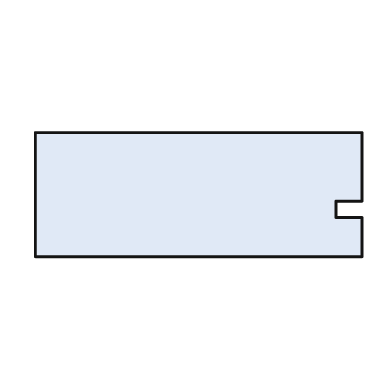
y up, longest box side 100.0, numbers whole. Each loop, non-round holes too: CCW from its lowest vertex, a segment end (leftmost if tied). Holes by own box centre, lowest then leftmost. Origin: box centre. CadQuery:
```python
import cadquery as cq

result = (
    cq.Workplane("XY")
    .moveTo(-50.0, -19.0)
    .lineTo(50.0, -19.0)
    .lineTo(50.0, -7.0)
    .lineTo(42.0, -7.0)
    .lineTo(42.0, -2.0)
    .lineTo(50.0, -2.0)
    .lineTo(50.0, 19.0)
    .lineTo(-50.0, 19.0)
    .close()
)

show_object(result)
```